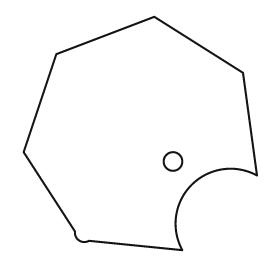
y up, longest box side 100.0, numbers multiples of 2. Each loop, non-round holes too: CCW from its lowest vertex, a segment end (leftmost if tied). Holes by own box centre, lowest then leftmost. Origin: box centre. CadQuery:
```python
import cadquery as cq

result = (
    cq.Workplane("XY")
    .moveTo(18.0, -50.0)
    .threePointArc((22.0, -22.0), (50.0, -18.0))
    .lineTo(44.0, 26.0)
    .lineTo(6.0, 50.0)
    .lineTo(-36.0, 34.0)
    .lineTo(-50.0, -8.0)
    .lineTo(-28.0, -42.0)
    .threePointArc((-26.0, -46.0), (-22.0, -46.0))
    .close()
    .moveTo(14.0, -12.0)
    .circle(4.0)
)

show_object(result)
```